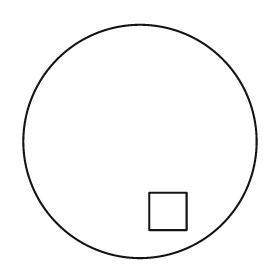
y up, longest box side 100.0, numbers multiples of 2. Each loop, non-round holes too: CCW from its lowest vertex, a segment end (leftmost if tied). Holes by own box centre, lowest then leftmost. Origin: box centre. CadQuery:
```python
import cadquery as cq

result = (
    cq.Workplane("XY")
    .moveTo(0.0, 0.0)
    .circle(50.0)
    .moveTo(4.0, -38.0)
    .lineTo(20.0, -38.0)
    .lineTo(20.0, -22.0)
    .lineTo(4.0, -22.0)
    .close()
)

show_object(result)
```